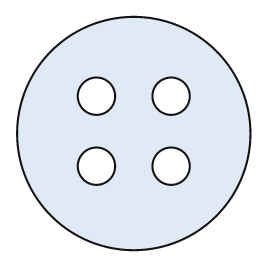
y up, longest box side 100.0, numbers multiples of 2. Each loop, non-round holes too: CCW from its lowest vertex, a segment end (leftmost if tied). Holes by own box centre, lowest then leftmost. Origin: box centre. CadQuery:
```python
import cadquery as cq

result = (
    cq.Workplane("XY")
    .moveTo(0.0, 0.0)
    .circle(50.0)
    .moveTo(-16.0, -14.0)
    .circle(8.0)
    .moveTo(16.0, -14.0)
    .circle(8.0)
    .moveTo(-16.0, 16.0)
    .circle(8.0)
    .moveTo(16.0, 16.0)
    .circle(8.0)
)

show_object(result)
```